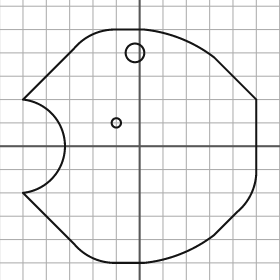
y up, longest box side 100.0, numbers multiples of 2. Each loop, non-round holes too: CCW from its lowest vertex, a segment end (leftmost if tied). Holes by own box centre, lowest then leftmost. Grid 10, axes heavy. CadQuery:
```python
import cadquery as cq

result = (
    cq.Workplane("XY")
    .moveTo(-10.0, -50.0)
    .lineTo(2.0, -50.0)
    .threePointArc((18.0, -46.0), (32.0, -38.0))
    .lineTo(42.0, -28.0)
    .threePointArc((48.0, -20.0), (50.0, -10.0))
    .lineTo(50.0, 20.0)
    .lineTo(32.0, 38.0)
    .threePointArc((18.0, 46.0), (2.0, 50.0))
    .lineTo(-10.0, 50.0)
    .threePointArc((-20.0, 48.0), (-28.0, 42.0))
    .lineTo(-50.0, 20.0)
    .threePointArc((-32.0, 0.0), (-50.0, -20.0))
    .lineTo(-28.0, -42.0)
    .threePointArc((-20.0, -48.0), (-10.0, -50.0))
    .close()
    .moveTo(-10.0, 10.0)
    .circle(2.0)
    .moveTo(-2.0, 40.0)
    .circle(4.0)
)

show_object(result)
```